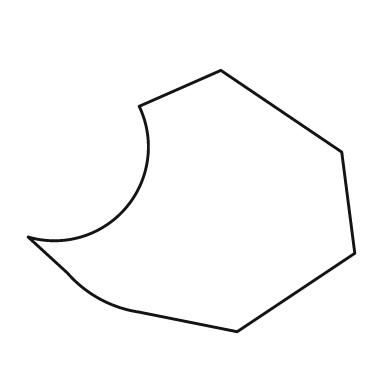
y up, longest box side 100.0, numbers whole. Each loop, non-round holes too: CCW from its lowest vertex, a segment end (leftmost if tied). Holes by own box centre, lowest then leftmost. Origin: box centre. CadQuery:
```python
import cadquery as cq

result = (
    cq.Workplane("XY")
    .moveTo(14.0, -40.0)
    .lineTo(50.0, -16.0)
    .lineTo(46.0, 15.0)
    .lineTo(9.0, 40.0)
    .lineTo(-16.0, 29.0)
    .threePointArc((-20.0, -2.0), (-50.0, -11.0))
    .lineTo(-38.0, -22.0)
    .threePointArc((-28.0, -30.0), (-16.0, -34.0))
    .close()
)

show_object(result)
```